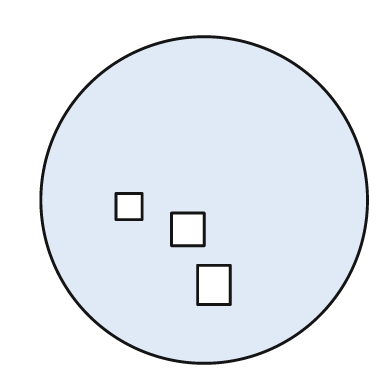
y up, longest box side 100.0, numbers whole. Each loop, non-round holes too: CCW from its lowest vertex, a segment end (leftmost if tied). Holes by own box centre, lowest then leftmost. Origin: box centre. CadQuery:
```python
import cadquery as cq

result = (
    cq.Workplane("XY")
    .moveTo(0.0, 0.0)
    .circle(50.0)
    .moveTo(-2.0, -32.0)
    .lineTo(8.0, -32.0)
    .lineTo(8.0, -20.0)
    .lineTo(-2.0, -20.0)
    .close()
    .moveTo(-10.0, -14.0)
    .lineTo(0.0, -14.0)
    .lineTo(0.0, -4.0)
    .lineTo(-10.0, -4.0)
    .close()
    .moveTo(-27.0, -6.0)
    .lineTo(-19.0, -6.0)
    .lineTo(-19.0, 2.0)
    .lineTo(-27.0, 2.0)
    .close()
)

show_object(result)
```